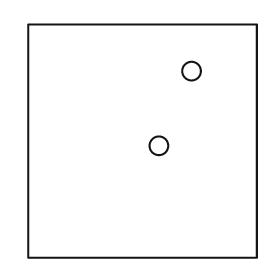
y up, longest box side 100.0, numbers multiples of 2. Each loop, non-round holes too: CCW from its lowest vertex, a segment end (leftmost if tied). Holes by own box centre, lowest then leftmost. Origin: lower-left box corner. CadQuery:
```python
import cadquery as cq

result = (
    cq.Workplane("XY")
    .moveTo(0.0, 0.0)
    .lineTo(98.0, 0.0)
    .lineTo(98.0, 100.0)
    .lineTo(0.0, 100.0)
    .close()
    .moveTo(56.0, 48.0)
    .circle(4.0)
    .moveTo(70.0, 80.0)
    .circle(4.0)
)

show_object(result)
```